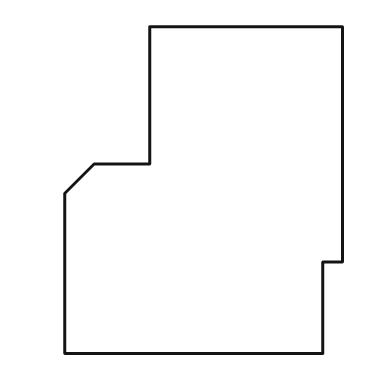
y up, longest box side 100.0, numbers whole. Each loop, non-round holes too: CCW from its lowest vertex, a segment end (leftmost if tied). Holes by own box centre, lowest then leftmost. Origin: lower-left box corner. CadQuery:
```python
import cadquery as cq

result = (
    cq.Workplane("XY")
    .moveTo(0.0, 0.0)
    .lineTo(79.0, 0.0)
    .lineTo(79.0, 28.0)
    .lineTo(85.0, 28.0)
    .lineTo(85.0, 100.0)
    .lineTo(26.0, 100.0)
    .lineTo(26.0, 58.0)
    .lineTo(9.0, 58.0)
    .lineTo(0.0, 49.0)
    .close()
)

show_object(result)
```